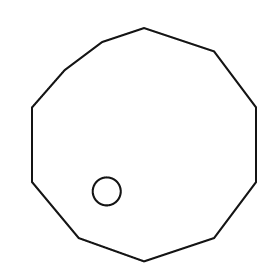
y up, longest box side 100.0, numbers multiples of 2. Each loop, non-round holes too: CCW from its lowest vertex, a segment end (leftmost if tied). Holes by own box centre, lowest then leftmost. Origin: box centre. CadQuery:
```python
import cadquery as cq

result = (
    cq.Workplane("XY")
    .moveTo(0.0, -50.0)
    .lineTo(30.0, -40.0)
    .lineTo(48.0, -16.0)
    .lineTo(48.0, 16.0)
    .lineTo(30.0, 40.0)
    .lineTo(0.0, 50.0)
    .lineTo(-18.0, 44.0)
    .lineTo(-34.0, 32.0)
    .lineTo(-48.0, 16.0)
    .lineTo(-48.0, -16.0)
    .lineTo(-28.0, -40.0)
    .close()
    .moveTo(-16.0, -20.0)
    .circle(6.0)
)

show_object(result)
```